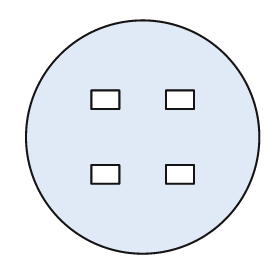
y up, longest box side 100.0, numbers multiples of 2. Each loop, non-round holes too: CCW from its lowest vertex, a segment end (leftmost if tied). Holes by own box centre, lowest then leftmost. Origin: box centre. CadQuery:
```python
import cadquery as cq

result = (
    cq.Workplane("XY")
    .moveTo(0.0, 0.0)
    .circle(50.0)
    .moveTo(-22.0, -20.0)
    .lineTo(-10.0, -20.0)
    .lineTo(-10.0, -12.0)
    .lineTo(-22.0, -12.0)
    .close()
    .moveTo(10.0, -20.0)
    .lineTo(22.0, -20.0)
    .lineTo(22.0, -12.0)
    .lineTo(10.0, -12.0)
    .close()
    .moveTo(-22.0, 12.0)
    .lineTo(-10.0, 12.0)
    .lineTo(-10.0, 20.0)
    .lineTo(-22.0, 20.0)
    .close()
    .moveTo(10.0, 12.0)
    .lineTo(22.0, 12.0)
    .lineTo(22.0, 20.0)
    .lineTo(10.0, 20.0)
    .close()
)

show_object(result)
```